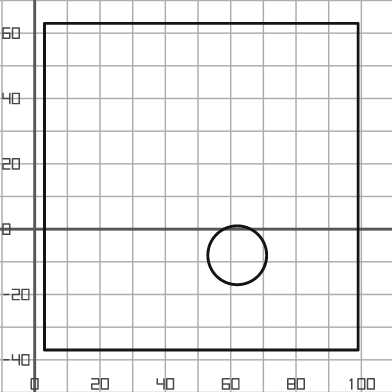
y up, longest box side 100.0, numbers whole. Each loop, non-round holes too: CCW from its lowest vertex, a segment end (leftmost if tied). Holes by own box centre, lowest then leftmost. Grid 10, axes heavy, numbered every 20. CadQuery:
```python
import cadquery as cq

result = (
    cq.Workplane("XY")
    .moveTo(3.0, -37.0)
    .lineTo(99.0, -37.0)
    .lineTo(99.0, 63.0)
    .lineTo(3.0, 63.0)
    .close()
    .moveTo(62.0, -8.0)
    .circle(9.0)
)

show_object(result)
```